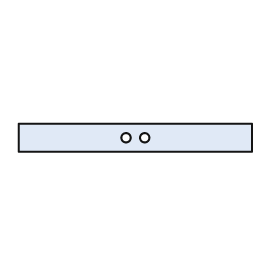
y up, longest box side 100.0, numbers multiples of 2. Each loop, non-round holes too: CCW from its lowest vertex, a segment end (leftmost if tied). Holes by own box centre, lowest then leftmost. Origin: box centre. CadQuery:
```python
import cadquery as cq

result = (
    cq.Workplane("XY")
    .moveTo(-50.0, -6.0)
    .lineTo(50.0, -6.0)
    .lineTo(50.0, 6.0)
    .lineTo(-50.0, 6.0)
    .close()
    .moveTo(-4.0, 0.0)
    .circle(2.0)
    .moveTo(4.0, 0.0)
    .circle(2.0)
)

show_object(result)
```